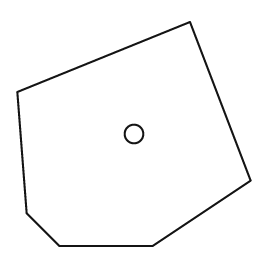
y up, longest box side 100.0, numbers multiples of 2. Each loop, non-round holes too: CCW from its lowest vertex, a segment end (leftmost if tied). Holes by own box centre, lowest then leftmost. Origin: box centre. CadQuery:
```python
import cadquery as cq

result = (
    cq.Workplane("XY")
    .moveTo(-32.0, -48.0)
    .lineTo(8.0, -48.0)
    .lineTo(50.0, -20.0)
    .lineTo(24.0, 48.0)
    .lineTo(-50.0, 18.0)
    .lineTo(-46.0, -34.0)
    .close()
    .moveTo(0.0, 0.0)
    .circle(4.0)
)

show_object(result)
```